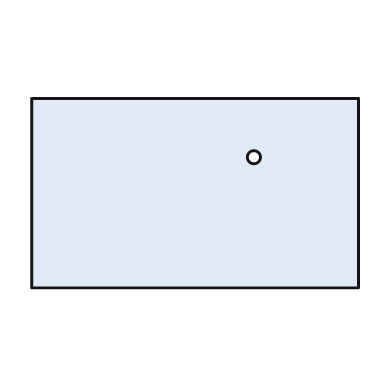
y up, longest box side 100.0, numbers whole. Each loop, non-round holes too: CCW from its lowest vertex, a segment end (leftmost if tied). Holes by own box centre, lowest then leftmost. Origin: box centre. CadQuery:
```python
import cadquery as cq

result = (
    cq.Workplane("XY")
    .moveTo(-50.0, -29.0)
    .lineTo(50.0, -29.0)
    .lineTo(50.0, 29.0)
    .lineTo(-50.0, 29.0)
    .close()
    .moveTo(18.0, 11.0)
    .circle(2.0)
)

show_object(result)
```